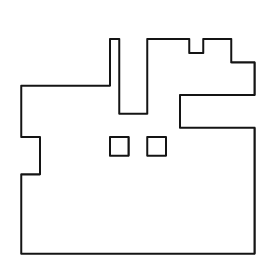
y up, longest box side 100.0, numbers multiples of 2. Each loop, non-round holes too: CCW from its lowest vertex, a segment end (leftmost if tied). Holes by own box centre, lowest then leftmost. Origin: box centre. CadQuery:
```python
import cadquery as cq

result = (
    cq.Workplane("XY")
    .moveTo(-50.0, -46.0)
    .lineTo(50.0, -46.0)
    .lineTo(50.0, 8.0)
    .lineTo(18.0, 8.0)
    .lineTo(18.0, 22.0)
    .lineTo(50.0, 22.0)
    .lineTo(50.0, 36.0)
    .lineTo(40.0, 36.0)
    .lineTo(40.0, 46.0)
    .lineTo(28.0, 46.0)
    .lineTo(28.0, 40.0)
    .lineTo(22.0, 40.0)
    .lineTo(22.0, 46.0)
    .lineTo(4.0, 46.0)
    .lineTo(4.0, 14.0)
    .lineTo(-8.0, 14.0)
    .lineTo(-8.0, 46.0)
    .lineTo(-12.0, 46.0)
    .lineTo(-12.0, 26.0)
    .lineTo(-50.0, 26.0)
    .lineTo(-50.0, 4.0)
    .lineTo(-42.0, 4.0)
    .lineTo(-42.0, -12.0)
    .lineTo(-50.0, -12.0)
    .close()
    .moveTo(-12.0, -4.0)
    .lineTo(-4.0, -4.0)
    .lineTo(-4.0, 4.0)
    .lineTo(-12.0, 4.0)
    .close()
    .moveTo(4.0, -4.0)
    .lineTo(12.0, -4.0)
    .lineTo(12.0, 4.0)
    .lineTo(4.0, 4.0)
    .close()
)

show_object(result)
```